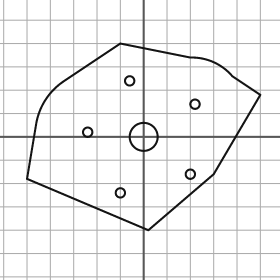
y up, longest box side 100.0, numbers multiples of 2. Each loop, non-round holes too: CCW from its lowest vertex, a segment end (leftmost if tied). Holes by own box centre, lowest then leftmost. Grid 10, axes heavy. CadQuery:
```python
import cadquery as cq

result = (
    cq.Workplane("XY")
    .moveTo(2.0, -40.0)
    .lineTo(30.0, -16.0)
    .lineTo(50.0, 18.0)
    .lineTo(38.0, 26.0)
    .threePointArc((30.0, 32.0), (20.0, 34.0))
    .lineTo(-10.0, 40.0)
    .lineTo(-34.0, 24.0)
    .threePointArc((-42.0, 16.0), (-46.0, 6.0))
    .lineTo(-50.0, -18.0)
    .close()
    .moveTo(-10.0, -24.0)
    .circle(2.0)
    .moveTo(20.0, -16.0)
    .circle(2.0)
    .moveTo(0.0, 0.0)
    .circle(6.0)
    .moveTo(-24.0, 2.0)
    .circle(2.0)
    .moveTo(22.0, 14.0)
    .circle(2.0)
    .moveTo(-6.0, 24.0)
    .circle(2.0)
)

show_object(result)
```